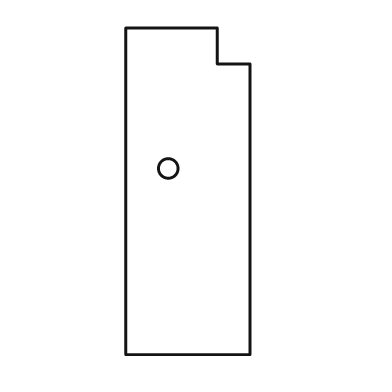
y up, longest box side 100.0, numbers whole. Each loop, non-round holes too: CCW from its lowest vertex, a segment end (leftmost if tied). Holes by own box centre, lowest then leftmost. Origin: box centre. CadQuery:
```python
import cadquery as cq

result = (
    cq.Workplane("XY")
    .moveTo(-19.0, -50.0)
    .lineTo(19.0, -50.0)
    .lineTo(19.0, 39.0)
    .lineTo(9.0, 39.0)
    .lineTo(9.0, 50.0)
    .lineTo(-19.0, 50.0)
    .close()
    .moveTo(-6.0, 7.0)
    .circle(3.0)
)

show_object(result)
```